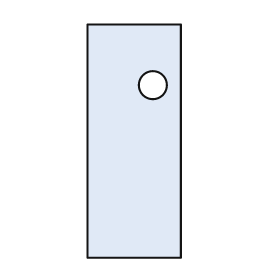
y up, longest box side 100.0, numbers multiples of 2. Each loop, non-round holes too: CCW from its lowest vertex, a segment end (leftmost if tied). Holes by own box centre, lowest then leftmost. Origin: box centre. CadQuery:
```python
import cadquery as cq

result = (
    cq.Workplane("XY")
    .moveTo(-20.0, -50.0)
    .lineTo(20.0, -50.0)
    .lineTo(20.0, 50.0)
    .lineTo(-20.0, 50.0)
    .close()
    .moveTo(8.0, 24.0)
    .circle(6.0)
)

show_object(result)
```